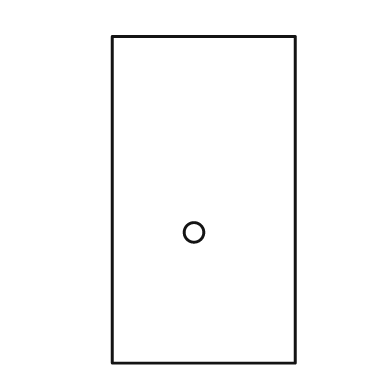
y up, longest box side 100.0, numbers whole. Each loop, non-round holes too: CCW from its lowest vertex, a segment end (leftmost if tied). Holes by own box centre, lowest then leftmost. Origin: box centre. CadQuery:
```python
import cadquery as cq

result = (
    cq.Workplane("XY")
    .moveTo(-28.0, -50.0)
    .lineTo(28.0, -50.0)
    .lineTo(28.0, 50.0)
    .lineTo(-28.0, 50.0)
    .close()
    .moveTo(-3.0, -10.0)
    .circle(3.0)
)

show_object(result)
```